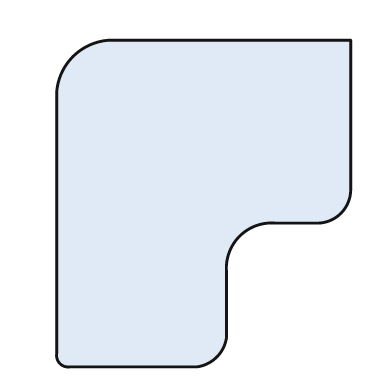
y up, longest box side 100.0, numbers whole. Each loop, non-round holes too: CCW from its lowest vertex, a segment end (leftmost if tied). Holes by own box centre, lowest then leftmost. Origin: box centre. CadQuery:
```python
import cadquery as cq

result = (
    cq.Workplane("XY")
    .moveTo(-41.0, -50.0)
    .lineTo(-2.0, -50.0)
    .threePointArc((4.0, -47.0), (7.0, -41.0))
    .lineTo(7.0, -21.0)
    .threePointArc((11.0, -10.0), (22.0, -6.0))
    .lineTo(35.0, -6.0)
    .threePointArc((42.0, -3.0), (45.0, 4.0))
    .lineTo(45.0, 50.0)
    .lineTo(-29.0, 50.0)
    .threePointArc((-40.0, 45.0), (-45.0, 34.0))
    .lineTo(-45.0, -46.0)
    .threePointArc((-44.0, -49.0), (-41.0, -50.0))
    .close()
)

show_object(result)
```